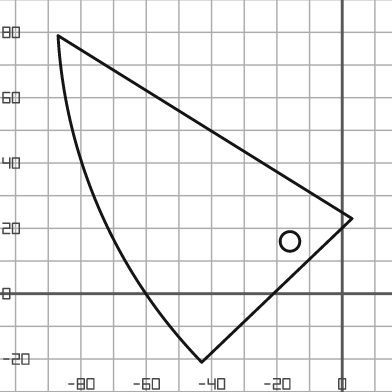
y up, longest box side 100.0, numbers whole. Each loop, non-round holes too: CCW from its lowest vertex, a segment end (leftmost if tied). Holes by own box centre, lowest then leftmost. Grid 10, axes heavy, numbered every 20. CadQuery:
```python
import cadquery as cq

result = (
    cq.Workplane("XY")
    .moveTo(-43.0, -21.0)
    .lineTo(3.0, 23.0)
    .lineTo(-87.0, 79.0)
    .threePointArc((-74.0, 25.0), (-43.0, -21.0))
    .close()
    .moveTo(-16.0, 16.0)
    .circle(3.0)
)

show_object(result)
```